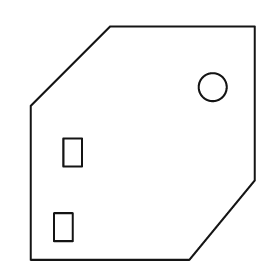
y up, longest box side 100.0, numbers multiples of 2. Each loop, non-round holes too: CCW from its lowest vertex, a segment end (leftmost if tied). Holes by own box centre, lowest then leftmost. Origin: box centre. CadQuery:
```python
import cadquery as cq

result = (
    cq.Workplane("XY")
    .moveTo(-48.0, -50.0)
    .lineTo(20.0, -50.0)
    .lineTo(48.0, -16.0)
    .lineTo(48.0, 50.0)
    .lineTo(-14.0, 50.0)
    .lineTo(-48.0, 16.0)
    .close()
    .moveTo(-38.0, -42.0)
    .lineTo(-30.0, -42.0)
    .lineTo(-30.0, -30.0)
    .lineTo(-38.0, -30.0)
    .close()
    .moveTo(-34.0, -10.0)
    .lineTo(-26.0, -10.0)
    .lineTo(-26.0, 2.0)
    .lineTo(-34.0, 2.0)
    .close()
    .moveTo(30.0, 24.0)
    .circle(6.0)
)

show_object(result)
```